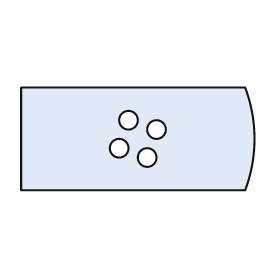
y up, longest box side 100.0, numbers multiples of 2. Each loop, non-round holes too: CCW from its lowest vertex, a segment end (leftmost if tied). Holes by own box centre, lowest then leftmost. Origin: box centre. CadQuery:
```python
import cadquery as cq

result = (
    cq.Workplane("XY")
    .moveTo(-50.0, -22.0)
    .lineTo(46.0, -22.0)
    .threePointArc((50.0, 0.0), (46.0, 22.0))
    .lineTo(-50.0, 22.0)
    .close()
    .moveTo(4.0, -8.0)
    .circle(4.0)
    .moveTo(-8.0, -4.0)
    .circle(4.0)
    .moveTo(8.0, 4.0)
    .circle(4.0)
    .moveTo(-4.0, 8.0)
    .circle(4.0)
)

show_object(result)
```